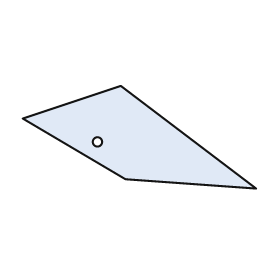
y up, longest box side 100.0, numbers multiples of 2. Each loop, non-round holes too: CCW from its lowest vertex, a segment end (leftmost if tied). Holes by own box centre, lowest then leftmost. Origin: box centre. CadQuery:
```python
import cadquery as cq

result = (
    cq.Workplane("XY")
    .moveTo(50.0, -22.0)
    .lineTo(-8.0, 22.0)
    .lineTo(-50.0, 8.0)
    .lineTo(-6.0, -18.0)
    .close()
    .moveTo(-18.0, -2.0)
    .circle(2.0)
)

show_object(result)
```